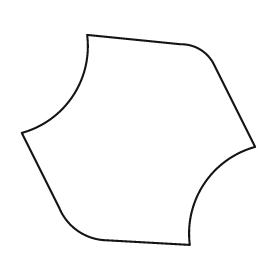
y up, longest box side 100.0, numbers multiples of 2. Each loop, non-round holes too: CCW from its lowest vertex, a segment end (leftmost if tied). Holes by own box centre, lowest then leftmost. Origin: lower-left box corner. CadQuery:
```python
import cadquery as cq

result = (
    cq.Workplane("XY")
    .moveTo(72.0, 0.0)
    .threePointArc((78.0, 26.0), (100.0, 42.0))
    .lineTo(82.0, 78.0)
    .threePointArc((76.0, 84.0), (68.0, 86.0))
    .lineTo(28.0, 90.0)
    .threePointArc((22.0, 64.0), (0.0, 48.0))
    .lineTo(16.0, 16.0)
    .threePointArc((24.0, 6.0), (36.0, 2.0))
    .close()
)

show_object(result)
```